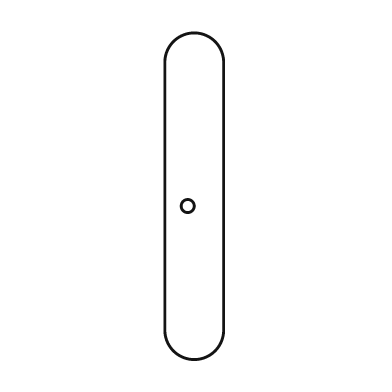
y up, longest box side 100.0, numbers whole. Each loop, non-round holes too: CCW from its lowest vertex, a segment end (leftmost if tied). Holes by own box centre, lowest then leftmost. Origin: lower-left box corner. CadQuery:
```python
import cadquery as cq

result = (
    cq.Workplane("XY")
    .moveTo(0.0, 9.0)
    .threePointArc((9.0, 0.0), (18.0, 9.0))
    .lineTo(18.0, 91.0)
    .threePointArc((9.0, 100.0), (0.0, 91.0))
    .close()
    .moveTo(7.0, 47.0)
    .circle(2.0)
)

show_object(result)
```